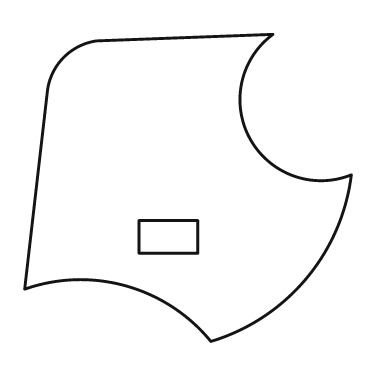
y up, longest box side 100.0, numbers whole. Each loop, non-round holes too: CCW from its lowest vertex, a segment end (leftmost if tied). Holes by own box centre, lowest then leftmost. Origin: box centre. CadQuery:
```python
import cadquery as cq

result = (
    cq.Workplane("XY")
    .moveTo(7.0, -47.0)
    .threePointArc((36.0, -28.0), (50.0, 4.0))
    .threePointArc((19.0, 15.0), (26.0, 47.0))
    .lineTo(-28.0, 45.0)
    .threePointArc((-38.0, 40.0), (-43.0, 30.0))
    .lineTo(-50.0, -31.0)
    .threePointArc((-19.0, -30.0), (7.0, -47.0))
    .close()
    .moveTo(-15.0, -20.0)
    .lineTo(3.0, -20.0)
    .lineTo(3.0, -10.0)
    .lineTo(-15.0, -10.0)
    .close()
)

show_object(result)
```